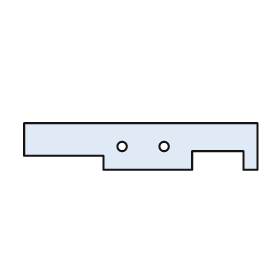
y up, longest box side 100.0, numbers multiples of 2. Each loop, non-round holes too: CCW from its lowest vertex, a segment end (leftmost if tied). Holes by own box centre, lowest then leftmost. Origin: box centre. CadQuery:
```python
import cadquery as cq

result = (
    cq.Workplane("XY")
    .moveTo(-16.0, -10.0)
    .lineTo(22.0, -10.0)
    .lineTo(22.0, -2.0)
    .lineTo(44.0, -2.0)
    .lineTo(44.0, -10.0)
    .lineTo(50.0, -10.0)
    .lineTo(50.0, 10.0)
    .lineTo(-50.0, 10.0)
    .lineTo(-50.0, -4.0)
    .lineTo(-16.0, -4.0)
    .close()
    .moveTo(-8.0, 0.0)
    .circle(2.0)
    .moveTo(10.0, 0.0)
    .circle(2.0)
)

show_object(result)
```